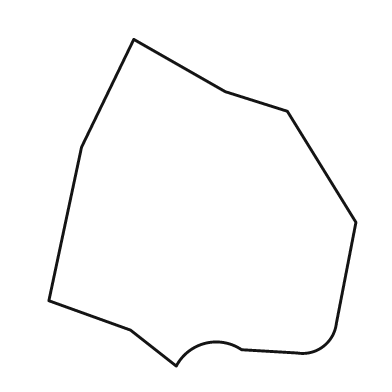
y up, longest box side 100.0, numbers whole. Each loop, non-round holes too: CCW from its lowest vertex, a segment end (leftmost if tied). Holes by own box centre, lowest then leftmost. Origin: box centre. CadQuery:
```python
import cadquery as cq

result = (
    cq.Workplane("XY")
    .moveTo(-8.0, -50.0)
    .threePointArc((1.0, -43.0), (12.0, -45.0))
    .lineTo(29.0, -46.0)
    .threePointArc((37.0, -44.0), (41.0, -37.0))
    .lineTo(47.0, -6.0)
    .lineTo(26.0, 28.0)
    .lineTo(7.0, 34.0)
    .lineTo(-21.0, 50.0)
    .lineTo(-37.0, 17.0)
    .lineTo(-47.0, -30.0)
    .lineTo(-22.0, -39.0)
    .close()
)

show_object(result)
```